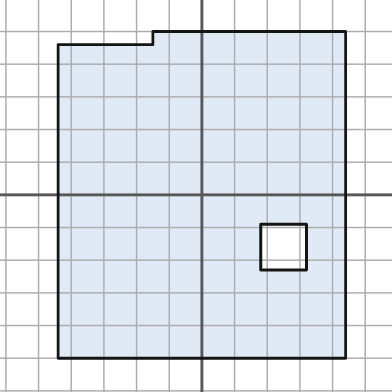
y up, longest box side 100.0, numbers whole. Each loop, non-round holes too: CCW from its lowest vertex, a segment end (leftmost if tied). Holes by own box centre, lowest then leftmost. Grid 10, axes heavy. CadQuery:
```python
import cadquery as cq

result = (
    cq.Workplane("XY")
    .moveTo(-44.0, -50.0)
    .lineTo(44.0, -50.0)
    .lineTo(44.0, 50.0)
    .lineTo(-15.0, 50.0)
    .lineTo(-15.0, 46.0)
    .lineTo(-44.0, 46.0)
    .close()
    .moveTo(18.0, -23.0)
    .lineTo(32.0, -23.0)
    .lineTo(32.0, -9.0)
    .lineTo(18.0, -9.0)
    .close()
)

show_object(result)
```